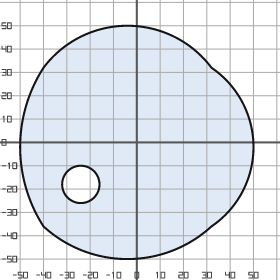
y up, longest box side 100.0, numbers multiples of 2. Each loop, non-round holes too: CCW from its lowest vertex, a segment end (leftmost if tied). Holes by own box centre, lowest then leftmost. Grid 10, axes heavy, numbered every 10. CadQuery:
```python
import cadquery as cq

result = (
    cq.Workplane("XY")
    .moveTo(-40.0, -36.0)
    .threePointArc((-4.0, -50.0), (32.0, -36.0))
    .threePointArc((50.0, -2.0), (32.0, 32.0))
    .threePointArc((-4.0, 50.0), (-40.0, 32.0))
    .threePointArc((-50.0, -2.0), (-40.0, -36.0))
    .close()
    .moveTo(-24.0, -18.0)
    .circle(8.0)
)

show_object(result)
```